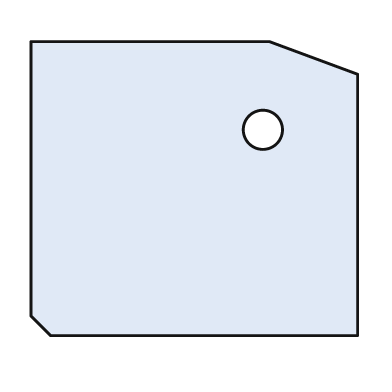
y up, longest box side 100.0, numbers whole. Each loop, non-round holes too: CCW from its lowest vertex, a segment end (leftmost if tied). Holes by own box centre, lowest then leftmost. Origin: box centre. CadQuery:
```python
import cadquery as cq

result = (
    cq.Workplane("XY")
    .moveTo(-44.0, -45.0)
    .lineTo(50.0, -45.0)
    .lineTo(50.0, 35.0)
    .lineTo(23.0, 45.0)
    .lineTo(-50.0, 45.0)
    .lineTo(-50.0, -39.0)
    .close()
    .moveTo(21.0, 18.0)
    .circle(6.0)
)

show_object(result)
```